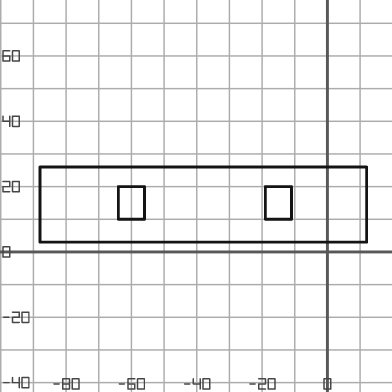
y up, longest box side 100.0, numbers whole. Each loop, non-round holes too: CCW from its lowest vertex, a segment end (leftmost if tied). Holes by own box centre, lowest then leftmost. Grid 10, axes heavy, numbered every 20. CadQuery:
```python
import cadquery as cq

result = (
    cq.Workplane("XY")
    .moveTo(-88.0, 3.0)
    .lineTo(12.0, 3.0)
    .lineTo(12.0, 26.0)
    .lineTo(-88.0, 26.0)
    .close()
    .moveTo(-64.0, 10.0)
    .lineTo(-56.0, 10.0)
    .lineTo(-56.0, 20.0)
    .lineTo(-64.0, 20.0)
    .close()
    .moveTo(-19.0, 10.0)
    .lineTo(-11.0, 10.0)
    .lineTo(-11.0, 20.0)
    .lineTo(-19.0, 20.0)
    .close()
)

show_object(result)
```